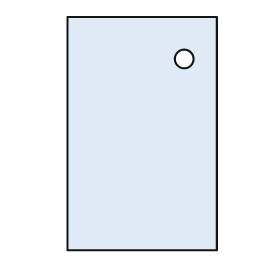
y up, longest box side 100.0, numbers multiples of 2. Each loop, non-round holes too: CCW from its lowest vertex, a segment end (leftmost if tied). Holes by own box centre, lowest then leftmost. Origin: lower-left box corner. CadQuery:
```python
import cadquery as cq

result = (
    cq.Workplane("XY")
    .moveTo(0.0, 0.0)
    .lineTo(64.0, 0.0)
    .lineTo(64.0, 100.0)
    .lineTo(0.0, 100.0)
    .close()
    .moveTo(50.0, 82.0)
    .circle(4.0)
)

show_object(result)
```